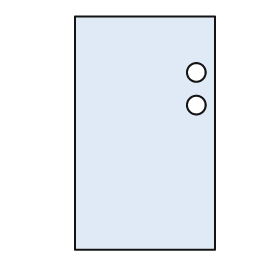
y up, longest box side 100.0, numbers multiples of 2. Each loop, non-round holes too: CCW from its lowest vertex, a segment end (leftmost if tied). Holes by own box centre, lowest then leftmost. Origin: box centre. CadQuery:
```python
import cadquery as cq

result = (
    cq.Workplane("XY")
    .moveTo(-30.0, -50.0)
    .lineTo(30.0, -50.0)
    .lineTo(30.0, 50.0)
    .lineTo(-30.0, 50.0)
    .close()
    .moveTo(22.0, 12.0)
    .circle(4.0)
    .moveTo(22.0, 26.0)
    .circle(4.0)
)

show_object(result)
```